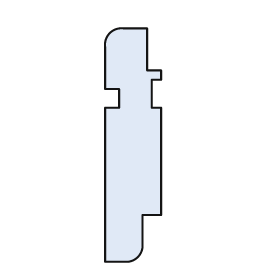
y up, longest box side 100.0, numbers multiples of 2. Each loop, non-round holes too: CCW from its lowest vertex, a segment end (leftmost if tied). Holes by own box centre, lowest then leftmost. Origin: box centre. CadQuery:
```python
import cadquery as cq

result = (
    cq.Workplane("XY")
    .moveTo(-12.0, -50.0)
    .lineTo(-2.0, -50.0)
    .threePointArc((2.0, -48.0), (4.0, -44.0))
    .lineTo(4.0, -30.0)
    .lineTo(12.0, -30.0)
    .lineTo(12.0, 16.0)
    .lineTo(8.0, 16.0)
    .lineTo(8.0, 28.0)
    .lineTo(12.0, 28.0)
    .lineTo(12.0, 32.0)
    .lineTo(6.0, 32.0)
    .lineTo(6.0, 50.0)
    .lineTo(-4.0, 50.0)
    .threePointArc((-10.0, 48.0), (-12.0, 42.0))
    .lineTo(-12.0, 24.0)
    .lineTo(-6.0, 24.0)
    .lineTo(-6.0, 16.0)
    .lineTo(-12.0, 16.0)
    .close()
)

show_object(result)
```